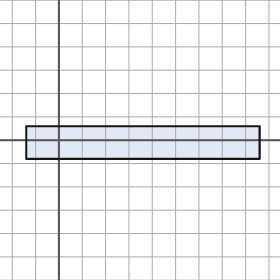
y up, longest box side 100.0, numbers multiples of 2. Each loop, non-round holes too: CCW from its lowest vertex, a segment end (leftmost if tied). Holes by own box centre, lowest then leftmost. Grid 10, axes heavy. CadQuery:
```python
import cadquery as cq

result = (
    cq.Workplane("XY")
    .moveTo(-14.0, -8.0)
    .lineTo(86.0, -8.0)
    .lineTo(86.0, 6.0)
    .lineTo(-14.0, 6.0)
    .close()
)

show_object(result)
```